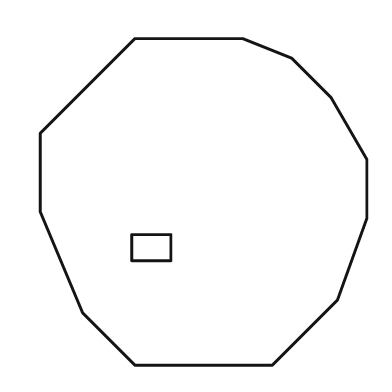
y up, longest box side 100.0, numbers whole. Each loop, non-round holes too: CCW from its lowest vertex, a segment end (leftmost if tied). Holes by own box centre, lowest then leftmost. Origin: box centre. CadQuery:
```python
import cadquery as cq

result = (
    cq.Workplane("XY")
    .moveTo(-21.0, -50.0)
    .lineTo(21.0, -50.0)
    .lineTo(41.0, -30.0)
    .lineTo(50.0, -5.0)
    .lineTo(50.0, 13.0)
    .lineTo(39.0, 32.0)
    .lineTo(27.0, 44.0)
    .lineTo(12.0, 50.0)
    .lineTo(-21.0, 50.0)
    .lineTo(-50.0, 21.0)
    .lineTo(-50.0, -3.0)
    .lineTo(-37.0, -34.0)
    .close()
    .moveTo(-22.0, -18.0)
    .lineTo(-10.0, -18.0)
    .lineTo(-10.0, -10.0)
    .lineTo(-22.0, -10.0)
    .close()
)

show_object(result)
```